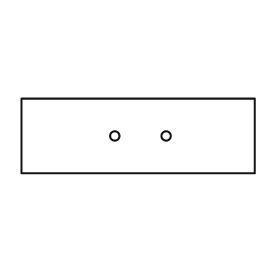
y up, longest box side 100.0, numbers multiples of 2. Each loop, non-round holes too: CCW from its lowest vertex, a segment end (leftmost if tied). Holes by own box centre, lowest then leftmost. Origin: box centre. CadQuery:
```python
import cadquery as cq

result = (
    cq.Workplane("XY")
    .moveTo(-50.0, -16.0)
    .lineTo(50.0, -16.0)
    .lineTo(50.0, 16.0)
    .lineTo(-50.0, 16.0)
    .close()
    .moveTo(-10.0, 0.0)
    .circle(2.0)
    .moveTo(12.0, 0.0)
    .circle(2.0)
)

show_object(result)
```